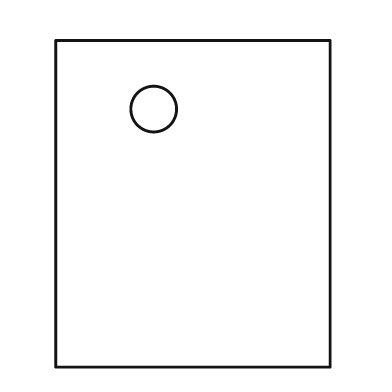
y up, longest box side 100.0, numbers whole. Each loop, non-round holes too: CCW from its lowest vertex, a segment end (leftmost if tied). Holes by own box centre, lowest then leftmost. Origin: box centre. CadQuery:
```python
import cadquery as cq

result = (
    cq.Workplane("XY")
    .moveTo(-42.0, -50.0)
    .lineTo(42.0, -50.0)
    .lineTo(42.0, 50.0)
    .lineTo(-42.0, 50.0)
    .close()
    .moveTo(-12.0, 29.0)
    .circle(7.0)
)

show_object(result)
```